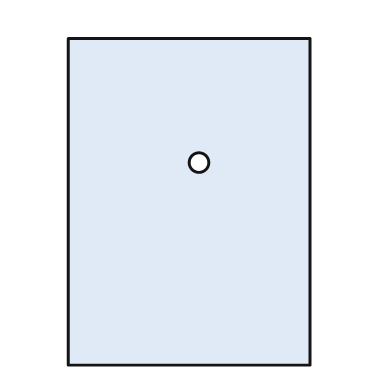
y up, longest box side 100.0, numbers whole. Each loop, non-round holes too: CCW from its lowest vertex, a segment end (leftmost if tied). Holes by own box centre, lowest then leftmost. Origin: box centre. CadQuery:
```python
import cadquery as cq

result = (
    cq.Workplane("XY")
    .moveTo(-37.0, -50.0)
    .lineTo(37.0, -50.0)
    .lineTo(37.0, 50.0)
    .lineTo(-37.0, 50.0)
    .close()
    .moveTo(3.0, 12.0)
    .circle(3.0)
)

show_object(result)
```